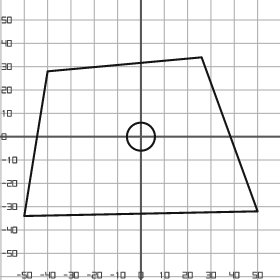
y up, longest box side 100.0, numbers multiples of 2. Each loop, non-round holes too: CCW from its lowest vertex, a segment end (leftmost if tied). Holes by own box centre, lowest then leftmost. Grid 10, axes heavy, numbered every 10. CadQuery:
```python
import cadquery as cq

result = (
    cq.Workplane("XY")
    .moveTo(-50.0, -34.0)
    .lineTo(50.0, -32.0)
    .lineTo(26.0, 34.0)
    .lineTo(-40.0, 28.0)
    .close()
    .moveTo(0.0, 0.0)
    .circle(6.0)
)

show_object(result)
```